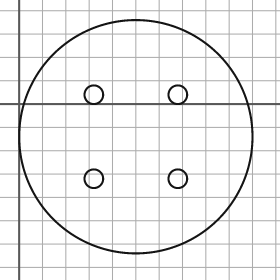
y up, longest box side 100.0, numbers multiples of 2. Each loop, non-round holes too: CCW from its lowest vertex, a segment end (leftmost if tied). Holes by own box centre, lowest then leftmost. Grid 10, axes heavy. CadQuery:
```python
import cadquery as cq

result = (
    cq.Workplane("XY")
    .moveTo(50.0, -14.0)
    .circle(50.0)
    .moveTo(32.0, -32.0)
    .circle(4.0)
    .moveTo(68.0, -32.0)
    .circle(4.0)
    .moveTo(32.0, 4.0)
    .circle(4.0)
    .moveTo(68.0, 4.0)
    .circle(4.0)
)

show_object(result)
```